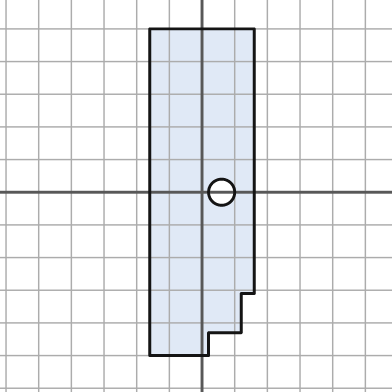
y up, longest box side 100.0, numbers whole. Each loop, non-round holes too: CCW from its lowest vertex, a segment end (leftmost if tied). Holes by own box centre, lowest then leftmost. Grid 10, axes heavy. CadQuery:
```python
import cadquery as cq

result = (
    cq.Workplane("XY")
    .moveTo(-16.0, -50.0)
    .lineTo(2.0, -50.0)
    .lineTo(2.0, -43.0)
    .lineTo(12.0, -43.0)
    .lineTo(12.0, -31.0)
    .lineTo(16.0, -31.0)
    .lineTo(16.0, 50.0)
    .lineTo(-16.0, 50.0)
    .close()
    .moveTo(6.0, 0.0)
    .circle(4.0)
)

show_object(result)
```